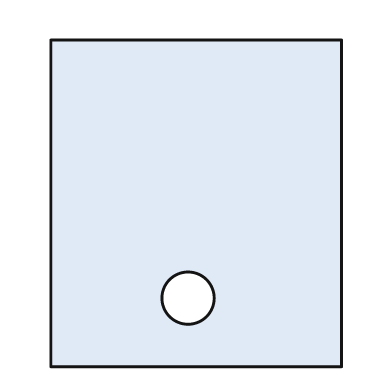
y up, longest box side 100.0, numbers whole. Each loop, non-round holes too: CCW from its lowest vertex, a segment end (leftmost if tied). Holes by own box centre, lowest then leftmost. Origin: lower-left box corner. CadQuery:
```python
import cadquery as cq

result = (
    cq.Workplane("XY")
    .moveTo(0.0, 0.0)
    .lineTo(89.0, 0.0)
    .lineTo(89.0, 100.0)
    .lineTo(0.0, 100.0)
    .close()
    .moveTo(42.0, 21.0)
    .circle(8.0)
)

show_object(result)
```